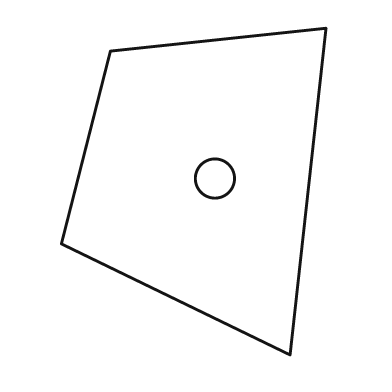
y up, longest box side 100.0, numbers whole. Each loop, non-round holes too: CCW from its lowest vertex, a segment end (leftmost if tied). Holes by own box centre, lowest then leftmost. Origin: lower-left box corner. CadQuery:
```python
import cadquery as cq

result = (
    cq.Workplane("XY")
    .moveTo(70.0, 0.0)
    .lineTo(81.0, 100.0)
    .lineTo(15.0, 93.0)
    .lineTo(0.0, 34.0)
    .close()
    .moveTo(47.0, 54.0)
    .circle(6.0)
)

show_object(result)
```